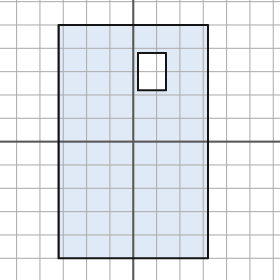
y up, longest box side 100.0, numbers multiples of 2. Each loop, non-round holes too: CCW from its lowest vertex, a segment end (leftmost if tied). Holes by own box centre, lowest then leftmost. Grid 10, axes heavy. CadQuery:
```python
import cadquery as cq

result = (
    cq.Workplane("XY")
    .moveTo(-32.0, -50.0)
    .lineTo(32.0, -50.0)
    .lineTo(32.0, 50.0)
    .lineTo(-32.0, 50.0)
    .close()
    .moveTo(2.0, 22.0)
    .lineTo(14.0, 22.0)
    .lineTo(14.0, 38.0)
    .lineTo(2.0, 38.0)
    .close()
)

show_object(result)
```